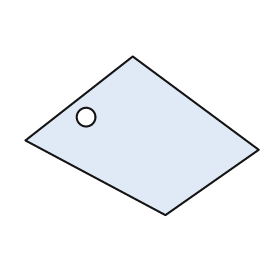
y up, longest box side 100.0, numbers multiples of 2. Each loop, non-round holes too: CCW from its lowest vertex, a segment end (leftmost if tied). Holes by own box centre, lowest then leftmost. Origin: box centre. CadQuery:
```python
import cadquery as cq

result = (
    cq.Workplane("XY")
    .moveTo(10.0, -34.0)
    .lineTo(50.0, -6.0)
    .lineTo(-4.0, 34.0)
    .lineTo(-50.0, -2.0)
    .close()
    .moveTo(-24.0, 8.0)
    .circle(4.0)
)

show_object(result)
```